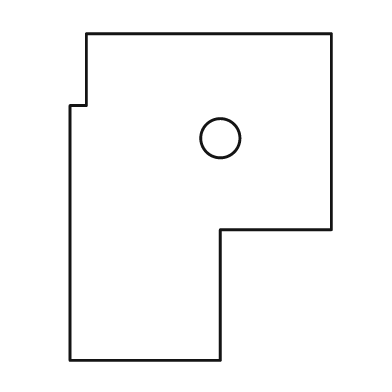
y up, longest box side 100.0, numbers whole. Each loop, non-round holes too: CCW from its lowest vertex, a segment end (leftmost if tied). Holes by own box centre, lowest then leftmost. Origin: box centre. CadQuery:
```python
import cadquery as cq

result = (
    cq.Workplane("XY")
    .moveTo(-40.0, -50.0)
    .lineTo(6.0, -50.0)
    .lineTo(6.0, -10.0)
    .lineTo(40.0, -10.0)
    .lineTo(40.0, 50.0)
    .lineTo(-35.0, 50.0)
    .lineTo(-35.0, 28.0)
    .lineTo(-40.0, 28.0)
    .close()
    .moveTo(6.0, 18.0)
    .circle(6.0)
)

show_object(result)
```